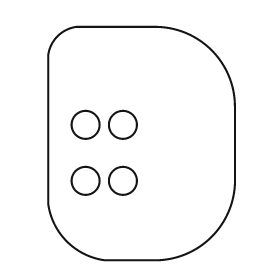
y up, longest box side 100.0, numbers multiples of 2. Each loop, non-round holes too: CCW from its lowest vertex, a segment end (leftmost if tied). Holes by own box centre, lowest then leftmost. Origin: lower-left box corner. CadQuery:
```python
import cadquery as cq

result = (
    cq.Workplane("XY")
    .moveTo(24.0, 0.0)
    .lineTo(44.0, 0.0)
    .threePointArc((70.0, 10.0), (80.0, 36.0))
    .lineTo(80.0, 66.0)
    .threePointArc((70.0, 90.0), (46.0, 100.0))
    .lineTo(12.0, 100.0)
    .threePointArc((4.0, 96.0), (0.0, 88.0))
    .lineTo(0.0, 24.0)
    .threePointArc((8.0, 8.0), (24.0, 0.0))
    .close()
    .moveTo(16.0, 34.0)
    .circle(6.0)
    .moveTo(32.0, 34.0)
    .circle(6.0)
    .moveTo(16.0, 58.0)
    .circle(6.0)
    .moveTo(32.0, 58.0)
    .circle(6.0)
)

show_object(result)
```